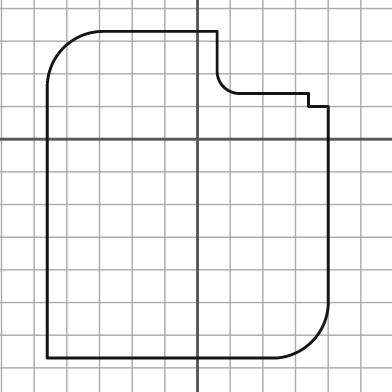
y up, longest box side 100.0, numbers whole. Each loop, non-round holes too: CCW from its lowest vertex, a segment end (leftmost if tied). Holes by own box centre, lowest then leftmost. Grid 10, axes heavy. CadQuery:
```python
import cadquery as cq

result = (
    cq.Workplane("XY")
    .moveTo(-46.0, -67.0)
    .lineTo(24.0, -67.0)
    .threePointArc((35.0, -62.0), (40.0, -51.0))
    .lineTo(40.0, 10.0)
    .lineTo(34.0, 10.0)
    .lineTo(34.0, 14.0)
    .lineTo(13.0, 14.0)
    .threePointArc((8.0, 16.0), (6.0, 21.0))
    .lineTo(6.0, 33.0)
    .lineTo(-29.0, 33.0)
    .threePointArc((-41.0, 28.0), (-46.0, 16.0))
    .close()
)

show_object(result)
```